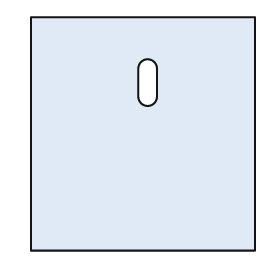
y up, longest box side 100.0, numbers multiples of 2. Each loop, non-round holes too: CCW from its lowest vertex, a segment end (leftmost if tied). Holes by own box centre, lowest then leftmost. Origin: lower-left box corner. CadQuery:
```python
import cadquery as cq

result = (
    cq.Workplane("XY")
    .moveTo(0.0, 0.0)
    .lineTo(96.0, 0.0)
    .lineTo(96.0, 100.0)
    .lineTo(0.0, 100.0)
    .close()
    .moveTo(46.0, 66.0)
    .threePointArc((50.0, 62.0), (54.0, 66.0))
    .lineTo(54.0, 78.0)
    .threePointArc((50.0, 82.0), (46.0, 78.0))
    .close()
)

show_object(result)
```